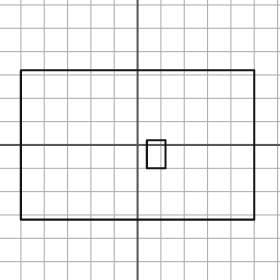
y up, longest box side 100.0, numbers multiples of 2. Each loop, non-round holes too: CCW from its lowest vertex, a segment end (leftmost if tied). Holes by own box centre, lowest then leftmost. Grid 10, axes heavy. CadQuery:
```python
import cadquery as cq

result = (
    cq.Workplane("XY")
    .moveTo(-50.0, -32.0)
    .lineTo(50.0, -32.0)
    .lineTo(50.0, 32.0)
    .lineTo(-50.0, 32.0)
    .close()
    .moveTo(4.0, -10.0)
    .lineTo(12.0, -10.0)
    .lineTo(12.0, 2.0)
    .lineTo(4.0, 2.0)
    .close()
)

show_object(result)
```